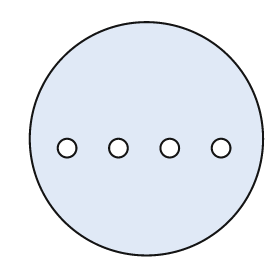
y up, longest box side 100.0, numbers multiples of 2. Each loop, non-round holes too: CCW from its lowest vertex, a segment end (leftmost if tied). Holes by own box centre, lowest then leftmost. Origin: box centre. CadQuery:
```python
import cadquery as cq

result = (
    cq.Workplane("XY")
    .moveTo(0.0, 0.0)
    .circle(50.0)
    .moveTo(-34.0, -4.0)
    .circle(4.0)
    .moveTo(-12.0, -4.0)
    .circle(4.0)
    .moveTo(10.0, -4.0)
    .circle(4.0)
    .moveTo(32.0, -4.0)
    .circle(4.0)
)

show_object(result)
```